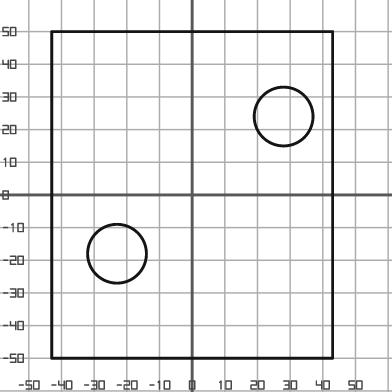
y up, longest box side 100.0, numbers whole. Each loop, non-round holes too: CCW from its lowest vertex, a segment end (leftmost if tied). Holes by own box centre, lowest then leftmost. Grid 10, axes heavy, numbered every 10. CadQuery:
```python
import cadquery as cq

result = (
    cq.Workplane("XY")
    .moveTo(-43.0, -50.0)
    .lineTo(43.0, -50.0)
    .lineTo(43.0, 50.0)
    .lineTo(-43.0, 50.0)
    .close()
    .moveTo(-23.0, -18.0)
    .circle(9.0)
    .moveTo(28.0, 24.0)
    .circle(9.0)
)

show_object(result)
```